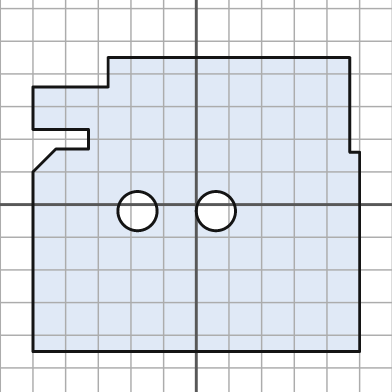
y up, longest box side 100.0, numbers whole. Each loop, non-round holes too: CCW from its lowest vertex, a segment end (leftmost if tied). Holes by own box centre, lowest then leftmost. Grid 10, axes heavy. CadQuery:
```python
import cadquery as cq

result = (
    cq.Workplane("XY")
    .moveTo(-50.0, -45.0)
    .lineTo(50.0, -45.0)
    .lineTo(50.0, 16.0)
    .lineTo(47.0, 16.0)
    .lineTo(47.0, 45.0)
    .lineTo(-27.0, 45.0)
    .lineTo(-27.0, 36.0)
    .lineTo(-50.0, 36.0)
    .lineTo(-50.0, 23.0)
    .lineTo(-33.0, 23.0)
    .lineTo(-33.0, 17.0)
    .lineTo(-43.0, 17.0)
    .lineTo(-50.0, 10.0)
    .close()
    .moveTo(-18.0, -2.0)
    .circle(6.0)
    .moveTo(6.0, -2.0)
    .circle(6.0)
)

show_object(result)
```